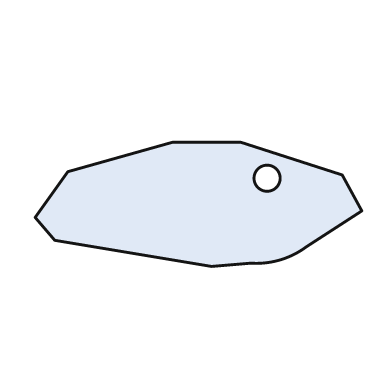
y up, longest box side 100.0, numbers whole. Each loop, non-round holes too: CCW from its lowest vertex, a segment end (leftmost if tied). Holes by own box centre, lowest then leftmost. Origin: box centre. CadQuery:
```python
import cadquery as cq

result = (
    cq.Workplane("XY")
    .moveTo(4.0, -19.0)
    .lineTo(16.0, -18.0)
    .threePointArc((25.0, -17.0), (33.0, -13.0))
    .lineTo(50.0, -2.0)
    .lineTo(44.0, 9.0)
    .lineTo(13.0, 19.0)
    .lineTo(-8.0, 19.0)
    .lineTo(-40.0, 10.0)
    .lineTo(-50.0, -4.0)
    .lineTo(-44.0, -11.0)
    .close()
    .moveTo(21.0, 8.0)
    .circle(4.0)
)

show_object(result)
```